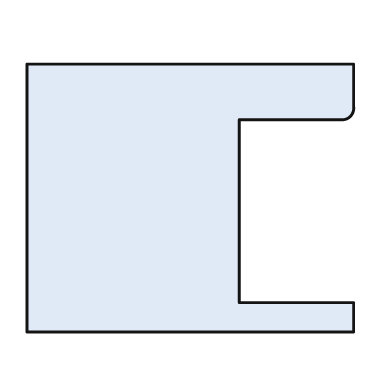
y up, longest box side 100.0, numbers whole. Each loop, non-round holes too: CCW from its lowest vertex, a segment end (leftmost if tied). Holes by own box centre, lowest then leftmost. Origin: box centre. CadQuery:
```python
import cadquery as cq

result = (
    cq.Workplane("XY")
    .moveTo(-50.0, -41.0)
    .lineTo(50.0, -41.0)
    .lineTo(50.0, -32.0)
    .lineTo(15.0, -32.0)
    .lineTo(15.0, 24.0)
    .lineTo(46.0, 24.0)
    .threePointArc((49.0, 25.0), (50.0, 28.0))
    .lineTo(50.0, 41.0)
    .lineTo(-50.0, 41.0)
    .close()
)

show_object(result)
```